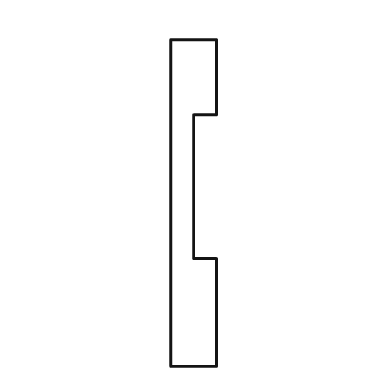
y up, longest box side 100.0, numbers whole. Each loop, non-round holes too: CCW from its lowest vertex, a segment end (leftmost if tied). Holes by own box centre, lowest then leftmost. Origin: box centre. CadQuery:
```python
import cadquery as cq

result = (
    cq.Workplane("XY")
    .moveTo(-7.0, -50.0)
    .lineTo(7.0, -50.0)
    .lineTo(7.0, -17.0)
    .lineTo(0.0, -17.0)
    .lineTo(0.0, 27.0)
    .lineTo(7.0, 27.0)
    .lineTo(7.0, 50.0)
    .lineTo(-7.0, 50.0)
    .close()
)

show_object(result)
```